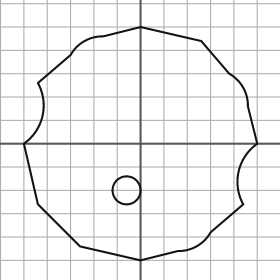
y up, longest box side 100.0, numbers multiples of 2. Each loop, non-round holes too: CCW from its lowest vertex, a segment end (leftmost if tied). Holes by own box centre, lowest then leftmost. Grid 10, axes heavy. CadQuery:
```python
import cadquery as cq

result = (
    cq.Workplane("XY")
    .moveTo(0.0, -50.0)
    .lineTo(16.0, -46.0)
    .threePointArc((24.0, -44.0), (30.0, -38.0))
    .lineTo(44.0, -26.0)
    .threePointArc((42.0, -12.0), (50.0, 0.0))
    .lineTo(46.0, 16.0)
    .threePointArc((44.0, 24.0), (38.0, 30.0))
    .lineTo(26.0, 44.0)
    .lineTo(0.0, 50.0)
    .lineTo(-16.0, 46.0)
    .threePointArc((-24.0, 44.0), (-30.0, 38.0))
    .lineTo(-44.0, 26.0)
    .threePointArc((-42.0, 12.0), (-50.0, 0.0))
    .lineTo(-44.0, -26.0)
    .lineTo(-26.0, -44.0)
    .close()
    .moveTo(-6.0, -20.0)
    .circle(6.0)
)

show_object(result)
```